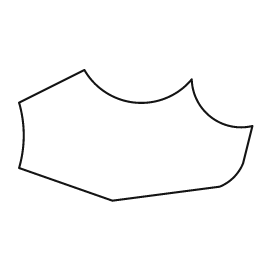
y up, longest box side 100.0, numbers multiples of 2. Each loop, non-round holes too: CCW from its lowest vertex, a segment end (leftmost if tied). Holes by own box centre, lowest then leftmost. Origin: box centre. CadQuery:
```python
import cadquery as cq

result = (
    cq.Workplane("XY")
    .moveTo(-10.0, -28.0)
    .lineTo(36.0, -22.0)
    .threePointArc((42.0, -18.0), (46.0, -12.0))
    .lineTo(50.0, 4.0)
    .threePointArc((32.0, 8.0), (24.0, 24.0))
    .threePointArc((0.0, 14.0), (-22.0, 28.0))
    .lineTo(-50.0, 14.0)
    .threePointArc((-48.0, 0.0), (-50.0, -14.0))
    .close()
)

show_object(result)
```